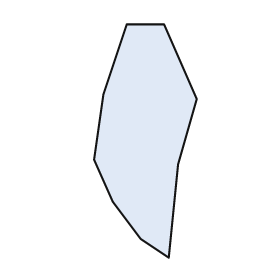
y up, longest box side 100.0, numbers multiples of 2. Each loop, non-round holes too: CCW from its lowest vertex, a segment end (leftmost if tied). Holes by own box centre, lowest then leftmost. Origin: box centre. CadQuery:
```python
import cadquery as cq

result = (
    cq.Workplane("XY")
    .moveTo(10.0, -50.0)
    .lineTo(14.0, -10.0)
    .lineTo(22.0, 18.0)
    .lineTo(8.0, 50.0)
    .lineTo(-8.0, 50.0)
    .lineTo(-18.0, 20.0)
    .lineTo(-22.0, -8.0)
    .lineTo(-14.0, -26.0)
    .lineTo(-2.0, -42.0)
    .close()
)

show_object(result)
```